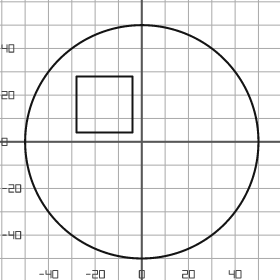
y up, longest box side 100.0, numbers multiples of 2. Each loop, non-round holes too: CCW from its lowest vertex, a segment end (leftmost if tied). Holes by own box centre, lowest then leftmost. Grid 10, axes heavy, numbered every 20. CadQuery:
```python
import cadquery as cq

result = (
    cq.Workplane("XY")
    .moveTo(0.0, 0.0)
    .circle(50.0)
    .moveTo(-28.0, 4.0)
    .lineTo(-4.0, 4.0)
    .lineTo(-4.0, 28.0)
    .lineTo(-28.0, 28.0)
    .close()
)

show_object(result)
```